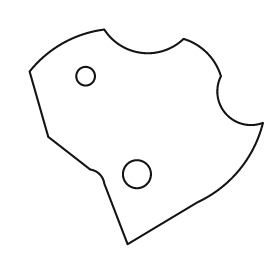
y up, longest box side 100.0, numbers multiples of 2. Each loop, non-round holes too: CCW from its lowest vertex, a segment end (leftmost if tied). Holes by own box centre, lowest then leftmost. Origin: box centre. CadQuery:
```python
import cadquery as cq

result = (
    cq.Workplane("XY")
    .moveTo(-8.0, -46.0)
    .lineTo(22.0, -28.0)
    .threePointArc((40.0, -14.0), (50.0, 6.0))
    .threePointArc((34.0, 10.0), (32.0, 26.0))
    .threePointArc((26.0, 36.0), (16.0, 42.0))
    .threePointArc((-2.0, 36.0), (-18.0, 46.0))
    .threePointArc((-36.0, 40.0), (-50.0, 28.0))
    .lineTo(-42.0, 0.0)
    .lineTo(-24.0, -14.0)
    .threePointArc((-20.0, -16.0), (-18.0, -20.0))
    .close()
    .moveTo(-4.0, -16.0)
    .circle(6.0)
    .moveTo(-26.0, 26.0)
    .circle(4.0)
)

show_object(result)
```